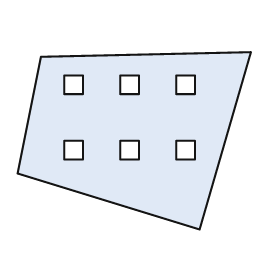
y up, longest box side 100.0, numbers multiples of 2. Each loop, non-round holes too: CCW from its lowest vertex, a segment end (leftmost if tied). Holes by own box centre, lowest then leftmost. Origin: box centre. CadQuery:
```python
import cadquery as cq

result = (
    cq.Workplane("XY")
    .moveTo(28.0, -38.0)
    .lineTo(50.0, 38.0)
    .lineTo(-40.0, 36.0)
    .lineTo(-50.0, -14.0)
    .close()
    .moveTo(-30.0, -8.0)
    .lineTo(-22.0, -8.0)
    .lineTo(-22.0, 0.0)
    .lineTo(-30.0, 0.0)
    .close()
    .moveTo(-6.0, -8.0)
    .lineTo(2.0, -8.0)
    .lineTo(2.0, 0.0)
    .lineTo(-6.0, 0.0)
    .close()
    .moveTo(18.0, -8.0)
    .lineTo(26.0, -8.0)
    .lineTo(26.0, 0.0)
    .lineTo(18.0, 0.0)
    .close()
    .moveTo(-30.0, 20.0)
    .lineTo(-22.0, 20.0)
    .lineTo(-22.0, 28.0)
    .lineTo(-30.0, 28.0)
    .close()
    .moveTo(-6.0, 20.0)
    .lineTo(2.0, 20.0)
    .lineTo(2.0, 28.0)
    .lineTo(-6.0, 28.0)
    .close()
    .moveTo(18.0, 20.0)
    .lineTo(26.0, 20.0)
    .lineTo(26.0, 28.0)
    .lineTo(18.0, 28.0)
    .close()
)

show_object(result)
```